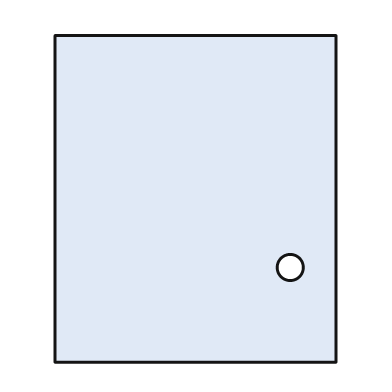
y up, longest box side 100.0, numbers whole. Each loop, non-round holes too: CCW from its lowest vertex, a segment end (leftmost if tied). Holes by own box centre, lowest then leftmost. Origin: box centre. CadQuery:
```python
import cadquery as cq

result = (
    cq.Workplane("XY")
    .moveTo(-43.0, -50.0)
    .lineTo(43.0, -50.0)
    .lineTo(43.0, 50.0)
    .lineTo(-43.0, 50.0)
    .close()
    .moveTo(29.0, -21.0)
    .circle(4.0)
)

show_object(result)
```